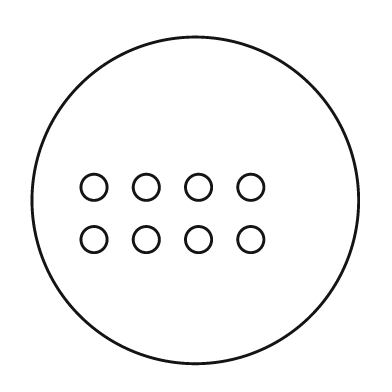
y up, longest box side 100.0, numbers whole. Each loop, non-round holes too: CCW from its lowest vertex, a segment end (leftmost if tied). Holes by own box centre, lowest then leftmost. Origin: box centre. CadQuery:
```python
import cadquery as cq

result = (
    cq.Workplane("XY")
    .moveTo(0.0, 0.0)
    .circle(50.0)
    .moveTo(-31.0, -12.0)
    .circle(4.0)
    .moveTo(-15.0, -12.0)
    .circle(4.0)
    .moveTo(1.0, -12.0)
    .circle(4.0)
    .moveTo(17.0, -12.0)
    .circle(4.0)
    .moveTo(-31.0, 4.0)
    .circle(4.0)
    .moveTo(-15.0, 4.0)
    .circle(4.0)
    .moveTo(1.0, 4.0)
    .circle(4.0)
    .moveTo(17.0, 4.0)
    .circle(4.0)
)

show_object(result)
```